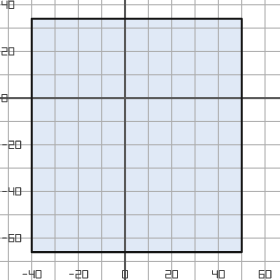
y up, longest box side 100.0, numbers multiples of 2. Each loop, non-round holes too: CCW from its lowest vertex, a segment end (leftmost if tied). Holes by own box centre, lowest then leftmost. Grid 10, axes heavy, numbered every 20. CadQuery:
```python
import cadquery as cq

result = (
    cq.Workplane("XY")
    .moveTo(-40.0, -66.0)
    .lineTo(50.0, -66.0)
    .lineTo(50.0, 34.0)
    .lineTo(-40.0, 34.0)
    .close()
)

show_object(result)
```